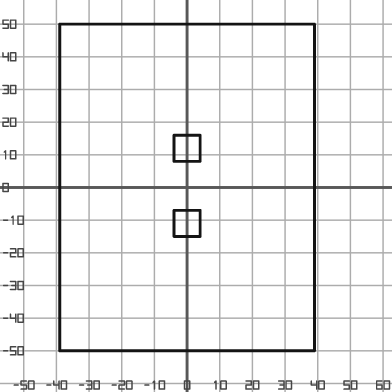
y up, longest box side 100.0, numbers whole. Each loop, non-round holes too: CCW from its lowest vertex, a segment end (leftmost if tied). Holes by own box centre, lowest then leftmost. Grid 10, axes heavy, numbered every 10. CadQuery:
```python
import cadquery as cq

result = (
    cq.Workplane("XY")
    .moveTo(-39.0, -50.0)
    .lineTo(39.0, -50.0)
    .lineTo(39.0, 50.0)
    .lineTo(-39.0, 50.0)
    .close()
    .moveTo(-4.0, -15.0)
    .lineTo(4.0, -15.0)
    .lineTo(4.0, -7.0)
    .lineTo(-4.0, -7.0)
    .close()
    .moveTo(-4.0, 8.0)
    .lineTo(4.0, 8.0)
    .lineTo(4.0, 16.0)
    .lineTo(-4.0, 16.0)
    .close()
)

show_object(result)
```